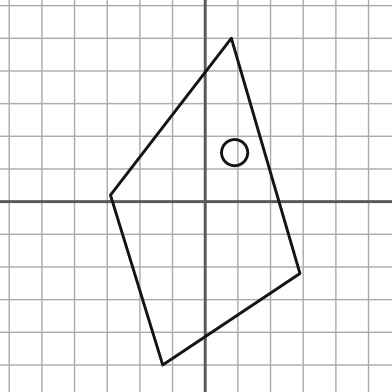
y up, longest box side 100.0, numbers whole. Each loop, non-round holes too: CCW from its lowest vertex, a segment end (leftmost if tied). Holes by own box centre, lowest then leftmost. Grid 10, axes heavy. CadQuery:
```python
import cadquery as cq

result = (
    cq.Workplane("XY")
    .moveTo(-13.0, -50.0)
    .lineTo(29.0, -22.0)
    .lineTo(8.0, 50.0)
    .lineTo(-29.0, 2.0)
    .close()
    .moveTo(9.0, 15.0)
    .circle(4.0)
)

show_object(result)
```